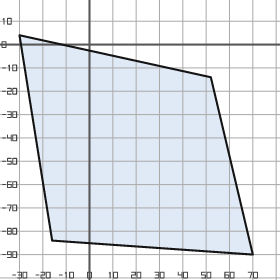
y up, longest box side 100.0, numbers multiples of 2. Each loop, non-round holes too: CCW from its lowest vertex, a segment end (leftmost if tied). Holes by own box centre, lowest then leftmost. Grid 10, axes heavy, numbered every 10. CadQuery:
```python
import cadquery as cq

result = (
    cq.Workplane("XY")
    .moveTo(70.0, -90.0)
    .lineTo(52.0, -14.0)
    .lineTo(-30.0, 4.0)
    .lineTo(-16.0, -84.0)
    .close()
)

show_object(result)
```